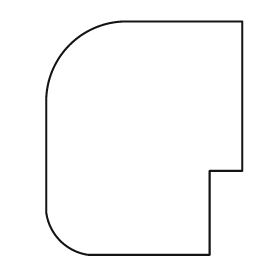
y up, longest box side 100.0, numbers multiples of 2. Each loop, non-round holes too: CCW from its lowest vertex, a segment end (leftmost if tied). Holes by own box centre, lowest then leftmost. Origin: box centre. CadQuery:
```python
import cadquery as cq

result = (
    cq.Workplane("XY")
    .moveTo(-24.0, -50.0)
    .lineTo(28.0, -50.0)
    .lineTo(28.0, -14.0)
    .lineTo(42.0, -14.0)
    .lineTo(42.0, 50.0)
    .lineTo(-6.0, 50.0)
    .threePointArc((-32.0, 40.0), (-42.0, 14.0))
    .lineTo(-42.0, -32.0)
    .threePointArc((-36.0, -44.0), (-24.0, -50.0))
    .close()
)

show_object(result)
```